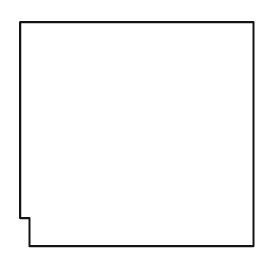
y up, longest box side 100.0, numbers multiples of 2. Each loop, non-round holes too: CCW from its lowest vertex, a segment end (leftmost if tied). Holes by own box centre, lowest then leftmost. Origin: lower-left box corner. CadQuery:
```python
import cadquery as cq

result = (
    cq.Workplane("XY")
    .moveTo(4.0, 0.0)
    .lineTo(100.0, 0.0)
    .lineTo(100.0, 96.0)
    .lineTo(0.0, 96.0)
    .lineTo(0.0, 12.0)
    .lineTo(4.0, 12.0)
    .close()
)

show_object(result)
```